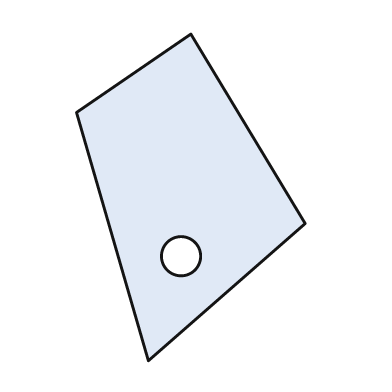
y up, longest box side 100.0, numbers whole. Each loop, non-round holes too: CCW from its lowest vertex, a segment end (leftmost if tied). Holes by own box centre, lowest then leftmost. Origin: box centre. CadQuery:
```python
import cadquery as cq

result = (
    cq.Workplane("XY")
    .moveTo(-13.0, -50.0)
    .lineTo(35.0, -8.0)
    .lineTo(0.0, 50.0)
    .lineTo(-35.0, 26.0)
    .close()
    .moveTo(-3.0, -18.0)
    .circle(6.0)
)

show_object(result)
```